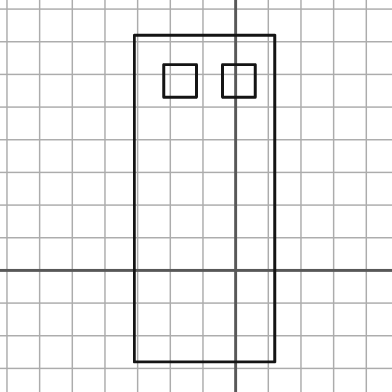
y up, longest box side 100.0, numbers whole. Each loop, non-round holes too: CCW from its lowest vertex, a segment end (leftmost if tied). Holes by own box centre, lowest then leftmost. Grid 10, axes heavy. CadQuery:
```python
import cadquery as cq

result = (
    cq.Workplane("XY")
    .moveTo(-31.0, -28.0)
    .lineTo(12.0, -28.0)
    .lineTo(12.0, 72.0)
    .lineTo(-31.0, 72.0)
    .close()
    .moveTo(-22.0, 53.0)
    .lineTo(-12.0, 53.0)
    .lineTo(-12.0, 63.0)
    .lineTo(-22.0, 63.0)
    .close()
    .moveTo(-4.0, 53.0)
    .lineTo(6.0, 53.0)
    .lineTo(6.0, 63.0)
    .lineTo(-4.0, 63.0)
    .close()
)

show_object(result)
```